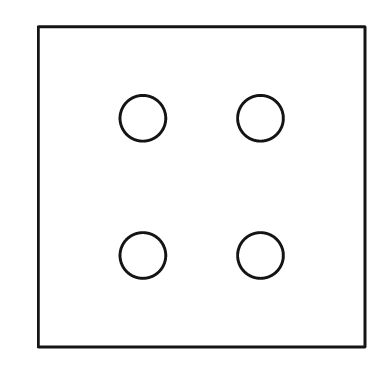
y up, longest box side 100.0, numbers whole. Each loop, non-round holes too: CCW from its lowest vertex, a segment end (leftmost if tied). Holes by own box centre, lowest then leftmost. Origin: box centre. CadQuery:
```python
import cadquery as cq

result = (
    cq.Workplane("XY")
    .moveTo(-50.0, -49.0)
    .lineTo(50.0, -49.0)
    .lineTo(50.0, 49.0)
    .lineTo(-50.0, 49.0)
    .close()
    .moveTo(-18.0, -21.0)
    .circle(7.0)
    .moveTo(18.0, -21.0)
    .circle(7.0)
    .moveTo(-18.0, 21.0)
    .circle(7.0)
    .moveTo(18.0, 21.0)
    .circle(7.0)
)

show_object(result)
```